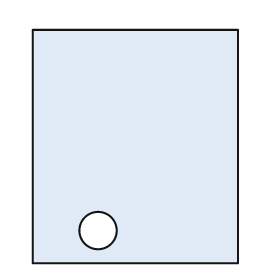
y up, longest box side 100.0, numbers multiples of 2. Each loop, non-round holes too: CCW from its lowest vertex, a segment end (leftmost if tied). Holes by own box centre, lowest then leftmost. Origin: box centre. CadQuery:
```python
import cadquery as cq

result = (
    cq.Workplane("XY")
    .moveTo(-44.0, -50.0)
    .lineTo(44.0, -50.0)
    .lineTo(44.0, 50.0)
    .lineTo(-44.0, 50.0)
    .close()
    .moveTo(-16.0, -36.0)
    .circle(8.0)
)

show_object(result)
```